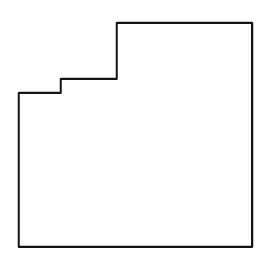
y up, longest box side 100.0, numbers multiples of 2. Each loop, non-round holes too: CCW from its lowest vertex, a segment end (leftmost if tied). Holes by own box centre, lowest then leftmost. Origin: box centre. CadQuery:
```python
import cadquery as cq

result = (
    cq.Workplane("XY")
    .moveTo(-50.0, -48.0)
    .lineTo(50.0, -48.0)
    .lineTo(50.0, 48.0)
    .lineTo(-8.0, 48.0)
    .lineTo(-8.0, 24.0)
    .lineTo(-32.0, 24.0)
    .lineTo(-32.0, 18.0)
    .lineTo(-50.0, 18.0)
    .close()
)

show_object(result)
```